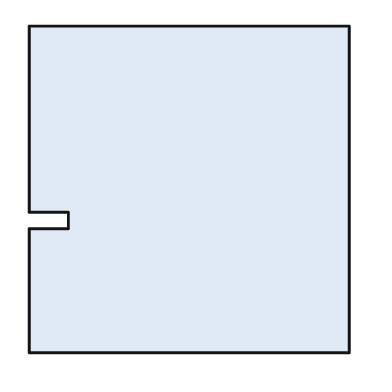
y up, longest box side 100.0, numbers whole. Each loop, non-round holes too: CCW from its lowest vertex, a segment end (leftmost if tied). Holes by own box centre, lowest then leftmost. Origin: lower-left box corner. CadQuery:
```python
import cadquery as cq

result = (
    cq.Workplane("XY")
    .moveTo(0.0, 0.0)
    .lineTo(98.0, 0.0)
    .lineTo(98.0, 100.0)
    .lineTo(0.0, 100.0)
    .lineTo(0.0, 43.0)
    .lineTo(12.0, 43.0)
    .lineTo(12.0, 38.0)
    .lineTo(0.0, 38.0)
    .close()
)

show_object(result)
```